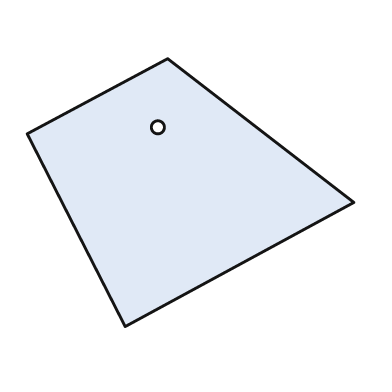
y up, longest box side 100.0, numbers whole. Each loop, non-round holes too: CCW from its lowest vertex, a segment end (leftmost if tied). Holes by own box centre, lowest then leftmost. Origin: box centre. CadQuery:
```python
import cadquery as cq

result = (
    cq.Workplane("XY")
    .moveTo(-20.0, -41.0)
    .lineTo(50.0, -3.0)
    .lineTo(-7.0, 41.0)
    .lineTo(-50.0, 18.0)
    .close()
    .moveTo(-10.0, 20.0)
    .circle(2.0)
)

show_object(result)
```